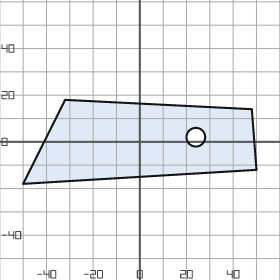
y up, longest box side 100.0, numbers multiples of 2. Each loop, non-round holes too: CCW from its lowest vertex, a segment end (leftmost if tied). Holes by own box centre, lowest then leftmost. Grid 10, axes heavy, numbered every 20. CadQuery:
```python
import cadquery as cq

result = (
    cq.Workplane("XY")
    .moveTo(-50.0, -18.0)
    .lineTo(50.0, -12.0)
    .lineTo(48.0, 14.0)
    .lineTo(-32.0, 18.0)
    .close()
    .moveTo(24.0, 2.0)
    .circle(4.0)
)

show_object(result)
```